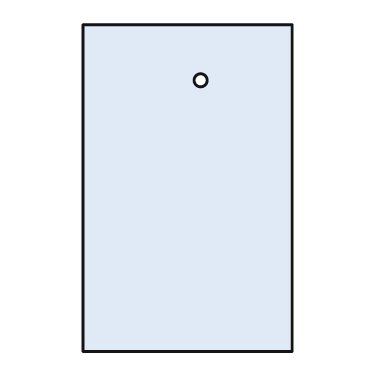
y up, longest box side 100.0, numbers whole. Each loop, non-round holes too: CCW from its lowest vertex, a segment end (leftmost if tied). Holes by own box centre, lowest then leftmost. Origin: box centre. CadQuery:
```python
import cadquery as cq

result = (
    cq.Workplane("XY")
    .moveTo(-32.0, -50.0)
    .lineTo(32.0, -50.0)
    .lineTo(32.0, 50.0)
    .lineTo(-32.0, 50.0)
    .close()
    .moveTo(4.0, 33.0)
    .circle(2.0)
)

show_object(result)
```